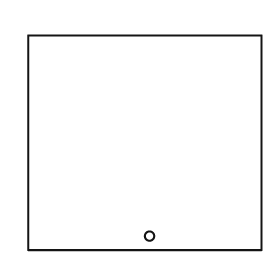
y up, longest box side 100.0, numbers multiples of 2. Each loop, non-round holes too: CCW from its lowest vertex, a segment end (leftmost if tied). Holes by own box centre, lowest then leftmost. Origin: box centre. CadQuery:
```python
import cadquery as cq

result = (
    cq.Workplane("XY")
    .moveTo(-50.0, -46.0)
    .lineTo(50.0, -46.0)
    .lineTo(50.0, 46.0)
    .lineTo(-50.0, 46.0)
    .close()
    .moveTo(2.0, -40.0)
    .circle(2.0)
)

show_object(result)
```